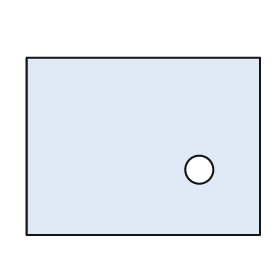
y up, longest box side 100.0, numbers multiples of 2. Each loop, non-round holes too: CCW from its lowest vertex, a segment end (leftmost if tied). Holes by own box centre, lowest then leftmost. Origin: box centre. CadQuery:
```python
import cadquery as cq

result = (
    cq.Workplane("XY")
    .moveTo(-50.0, -38.0)
    .lineTo(50.0, -38.0)
    .lineTo(50.0, 38.0)
    .lineTo(-50.0, 38.0)
    .close()
    .moveTo(24.0, -10.0)
    .circle(6.0)
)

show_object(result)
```